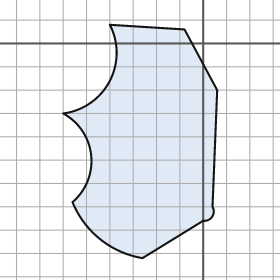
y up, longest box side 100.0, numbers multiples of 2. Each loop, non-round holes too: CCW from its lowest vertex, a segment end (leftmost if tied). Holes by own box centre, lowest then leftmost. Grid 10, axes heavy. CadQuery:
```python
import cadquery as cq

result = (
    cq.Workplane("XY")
    .moveTo(-26.0, -92.0)
    .lineTo(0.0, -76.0)
    .threePointArc((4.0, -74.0), (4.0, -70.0))
    .lineTo(6.0, -20.0)
    .lineTo(-8.0, 6.0)
    .lineTo(-40.0, 8.0)
    .threePointArc((-40.0, -16.0), (-60.0, -30.0))
    .threePointArc((-48.0, -48.0), (-56.0, -68.0))
    .threePointArc((-44.0, -84.0), (-26.0, -92.0))
    .close()
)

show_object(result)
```